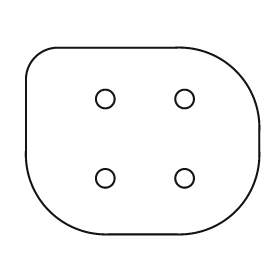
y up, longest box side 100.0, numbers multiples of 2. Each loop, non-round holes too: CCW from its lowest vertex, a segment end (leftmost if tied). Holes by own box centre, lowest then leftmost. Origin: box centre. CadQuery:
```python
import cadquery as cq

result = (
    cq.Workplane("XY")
    .moveTo(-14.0, -40.0)
    .lineTo(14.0, -40.0)
    .threePointArc((40.0, -30.0), (50.0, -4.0))
    .lineTo(50.0, 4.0)
    .threePointArc((40.0, 30.0), (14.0, 40.0))
    .lineTo(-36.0, 40.0)
    .threePointArc((-46.0, 36.0), (-50.0, 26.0))
    .lineTo(-50.0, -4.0)
    .threePointArc((-40.0, -30.0), (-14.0, -40.0))
    .close()
    .moveTo(-16.0, -16.0)
    .circle(4.0)
    .moveTo(18.0, -16.0)
    .circle(4.0)
    .moveTo(-16.0, 18.0)
    .circle(4.0)
    .moveTo(18.0, 18.0)
    .circle(4.0)
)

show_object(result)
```